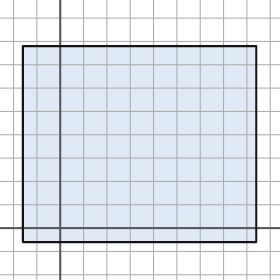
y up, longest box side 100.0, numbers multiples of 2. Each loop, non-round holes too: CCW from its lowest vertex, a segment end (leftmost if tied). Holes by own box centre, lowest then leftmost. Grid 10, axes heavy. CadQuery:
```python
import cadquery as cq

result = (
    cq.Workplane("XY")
    .moveTo(-16.0, -6.0)
    .lineTo(84.0, -6.0)
    .lineTo(84.0, 78.0)
    .lineTo(-16.0, 78.0)
    .close()
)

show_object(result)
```